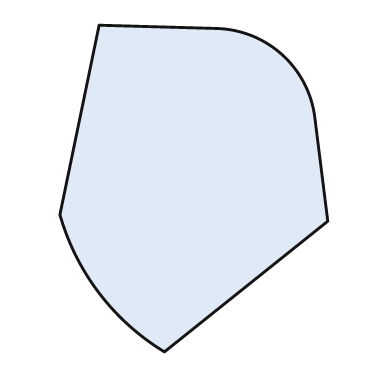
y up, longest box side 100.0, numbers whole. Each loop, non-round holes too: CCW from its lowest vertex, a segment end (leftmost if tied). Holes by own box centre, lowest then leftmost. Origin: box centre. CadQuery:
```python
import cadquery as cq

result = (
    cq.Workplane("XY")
    .moveTo(-9.0, -50.0)
    .lineTo(41.0, -10.0)
    .lineTo(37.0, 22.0)
    .threePointArc((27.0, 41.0), (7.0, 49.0))
    .lineTo(-29.0, 50.0)
    .lineTo(-41.0, -8.0)
    .threePointArc((-29.0, -32.0), (-9.0, -50.0))
    .close()
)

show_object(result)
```